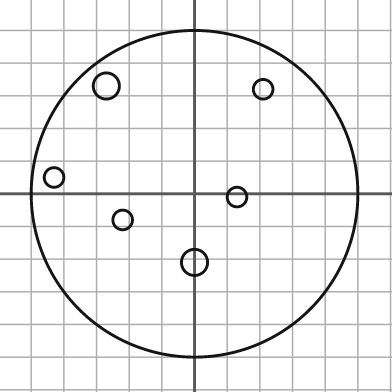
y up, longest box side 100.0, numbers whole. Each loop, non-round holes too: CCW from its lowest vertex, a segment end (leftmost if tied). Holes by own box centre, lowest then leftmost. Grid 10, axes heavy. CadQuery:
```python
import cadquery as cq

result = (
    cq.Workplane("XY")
    .moveTo(0.0, 0.0)
    .circle(50.0)
    .moveTo(0.0, -21.0)
    .circle(4.0)
    .moveTo(-22.0, -8.0)
    .circle(3.0)
    .moveTo(13.0, -1.0)
    .circle(3.0)
    .moveTo(-43.0, 5.0)
    .circle(3.0)
    .moveTo(21.0, 32.0)
    .circle(3.0)
    .moveTo(-27.0, 33.0)
    .circle(4.0)
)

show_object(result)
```